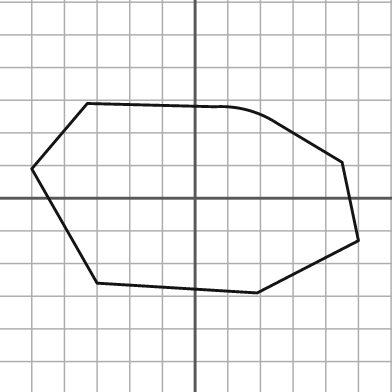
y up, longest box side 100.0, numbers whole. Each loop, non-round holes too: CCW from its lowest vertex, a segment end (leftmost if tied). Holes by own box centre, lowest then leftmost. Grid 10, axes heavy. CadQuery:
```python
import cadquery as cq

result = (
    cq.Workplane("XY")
    .moveTo(19.0, -29.0)
    .lineTo(50.0, -13.0)
    .lineTo(45.0, 11.0)
    .lineTo(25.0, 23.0)
    .threePointArc((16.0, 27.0), (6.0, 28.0))
    .lineTo(-33.0, 29.0)
    .lineTo(-50.0, 9.0)
    .lineTo(-30.0, -26.0)
    .close()
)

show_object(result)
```